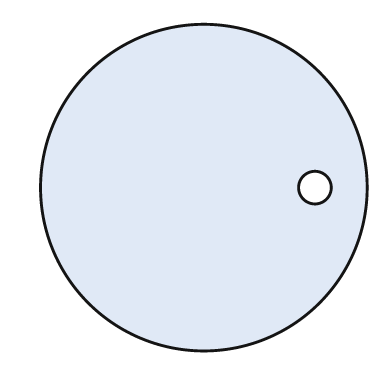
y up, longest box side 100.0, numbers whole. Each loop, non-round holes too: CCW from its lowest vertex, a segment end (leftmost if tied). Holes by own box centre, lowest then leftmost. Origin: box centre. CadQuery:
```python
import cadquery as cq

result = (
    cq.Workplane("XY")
    .moveTo(0.0, 0.0)
    .circle(50.0)
    .moveTo(34.0, 0.0)
    .circle(5.0)
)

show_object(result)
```